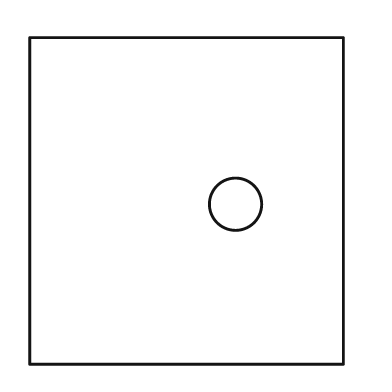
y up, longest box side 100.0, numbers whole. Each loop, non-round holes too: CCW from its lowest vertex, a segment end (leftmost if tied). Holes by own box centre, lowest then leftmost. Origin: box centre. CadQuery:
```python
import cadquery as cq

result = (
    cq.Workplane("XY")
    .moveTo(-48.0, -50.0)
    .lineTo(48.0, -50.0)
    .lineTo(48.0, 50.0)
    .lineTo(-48.0, 50.0)
    .close()
    .moveTo(15.0, -1.0)
    .circle(8.0)
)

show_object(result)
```